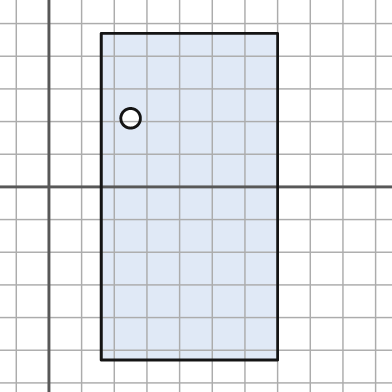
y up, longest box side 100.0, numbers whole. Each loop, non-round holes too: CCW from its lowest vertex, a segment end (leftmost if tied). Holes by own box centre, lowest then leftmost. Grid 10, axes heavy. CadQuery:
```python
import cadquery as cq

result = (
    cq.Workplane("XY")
    .moveTo(16.0, -53.0)
    .lineTo(70.0, -53.0)
    .lineTo(70.0, 47.0)
    .lineTo(16.0, 47.0)
    .close()
    .moveTo(25.0, 21.0)
    .circle(3.0)
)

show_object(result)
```